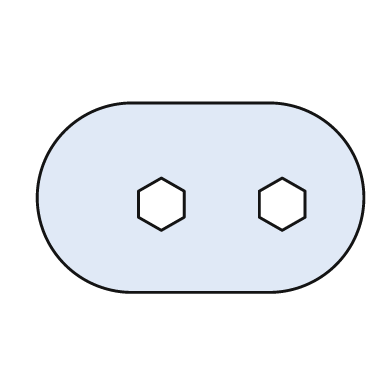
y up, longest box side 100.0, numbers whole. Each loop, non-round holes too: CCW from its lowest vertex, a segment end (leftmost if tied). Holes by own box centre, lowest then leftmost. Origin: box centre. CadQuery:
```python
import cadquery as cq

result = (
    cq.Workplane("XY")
    .moveTo(-21.0, -29.0)
    .lineTo(21.0, -29.0)
    .threePointArc((50.0, 0.0), (21.0, 29.0))
    .lineTo(-21.0, 29.0)
    .threePointArc((-50.0, 0.0), (-21.0, -29.0))
    .close()
    .moveTo(-12.0, -10.0)
    .lineTo(-5.0, -6.0)
    .lineTo(-5.0, 2.0)
    .lineTo(-12.0, 6.0)
    .lineTo(-19.0, 2.0)
    .lineTo(-19.0, -6.0)
    .close()
    .moveTo(25.0, -10.0)
    .lineTo(32.0, -6.0)
    .lineTo(32.0, 2.0)
    .lineTo(25.0, 6.0)
    .lineTo(18.0, 2.0)
    .lineTo(18.0, -6.0)
    .close()
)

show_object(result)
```